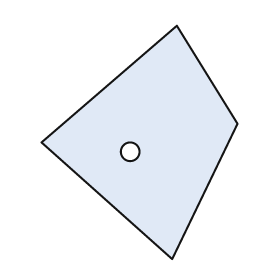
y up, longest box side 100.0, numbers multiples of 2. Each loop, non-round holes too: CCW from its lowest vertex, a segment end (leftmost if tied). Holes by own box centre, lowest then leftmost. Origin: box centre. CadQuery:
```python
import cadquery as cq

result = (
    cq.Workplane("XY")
    .moveTo(14.0, -50.0)
    .lineTo(42.0, 8.0)
    .lineTo(16.0, 50.0)
    .lineTo(-42.0, 0.0)
    .close()
    .moveTo(-4.0, -4.0)
    .circle(4.0)
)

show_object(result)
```